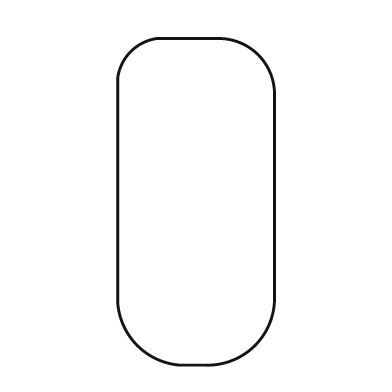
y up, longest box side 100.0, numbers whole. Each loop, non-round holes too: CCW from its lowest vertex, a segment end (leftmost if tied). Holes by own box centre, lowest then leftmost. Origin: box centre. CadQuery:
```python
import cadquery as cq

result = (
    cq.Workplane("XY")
    .moveTo(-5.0, -50.0)
    .lineTo(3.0, -50.0)
    .threePointArc((18.0, -44.0), (24.0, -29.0))
    .lineTo(24.0, 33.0)
    .threePointArc((19.0, 45.0), (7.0, 50.0))
    .lineTo(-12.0, 50.0)
    .threePointArc((-20.0, 46.0), (-24.0, 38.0))
    .lineTo(-24.0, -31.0)
    .threePointArc((-18.0, -44.0), (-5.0, -50.0))
    .close()
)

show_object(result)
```